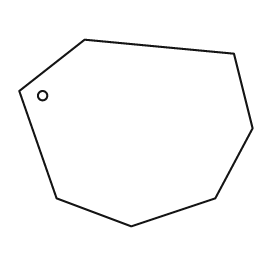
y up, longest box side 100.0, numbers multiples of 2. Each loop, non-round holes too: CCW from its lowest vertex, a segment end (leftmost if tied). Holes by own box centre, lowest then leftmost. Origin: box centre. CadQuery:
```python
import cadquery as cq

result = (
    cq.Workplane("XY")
    .moveTo(-2.0, -40.0)
    .lineTo(34.0, -28.0)
    .lineTo(50.0, 2.0)
    .lineTo(42.0, 34.0)
    .lineTo(-22.0, 40.0)
    .lineTo(-50.0, 18.0)
    .lineTo(-34.0, -28.0)
    .close()
    .moveTo(-40.0, 16.0)
    .circle(2.0)
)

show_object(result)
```